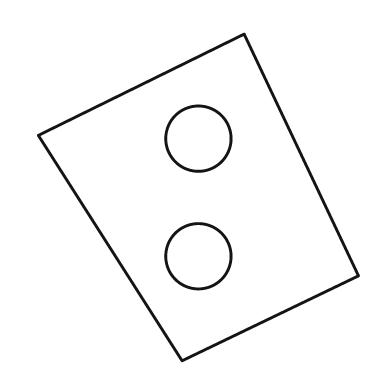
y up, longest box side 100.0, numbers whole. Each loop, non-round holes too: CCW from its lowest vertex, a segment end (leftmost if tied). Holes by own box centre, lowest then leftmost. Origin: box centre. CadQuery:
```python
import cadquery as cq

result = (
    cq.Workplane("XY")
    .moveTo(-5.0, -50.0)
    .lineTo(49.0, -24.0)
    .lineTo(14.0, 50.0)
    .lineTo(-49.0, 19.0)
    .close()
    .moveTo(0.0, -18.0)
    .circle(10.0)
    .moveTo(0.0, 18.0)
    .circle(10.0)
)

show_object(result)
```